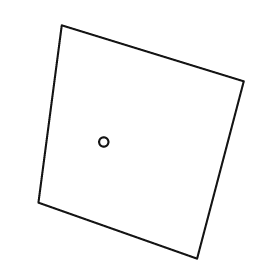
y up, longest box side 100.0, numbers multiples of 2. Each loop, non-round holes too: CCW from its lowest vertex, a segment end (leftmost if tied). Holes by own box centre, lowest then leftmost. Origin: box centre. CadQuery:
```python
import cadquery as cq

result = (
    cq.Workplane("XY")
    .moveTo(24.0, -50.0)
    .lineTo(44.0, 26.0)
    .lineTo(-34.0, 50.0)
    .lineTo(-44.0, -26.0)
    .close()
    .moveTo(-16.0, 0.0)
    .circle(2.0)
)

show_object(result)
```